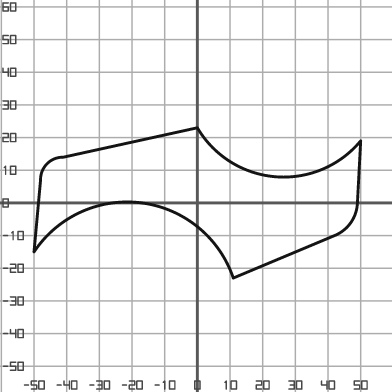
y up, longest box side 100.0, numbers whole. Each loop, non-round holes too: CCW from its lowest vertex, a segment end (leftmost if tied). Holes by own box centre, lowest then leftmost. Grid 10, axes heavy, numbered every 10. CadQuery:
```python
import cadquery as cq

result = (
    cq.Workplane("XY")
    .moveTo(11.0, -23.0)
    .lineTo(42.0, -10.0)
    .threePointArc((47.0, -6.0), (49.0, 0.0))
    .lineTo(50.0, 19.0)
    .threePointArc((24.0, 8.0), (0.0, 23.0))
    .lineTo(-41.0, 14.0)
    .threePointArc((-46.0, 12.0), (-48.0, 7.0))
    .lineTo(-50.0, -15.0)
    .threePointArc((-17.0, 0.0), (11.0, -23.0))
    .close()
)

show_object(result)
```